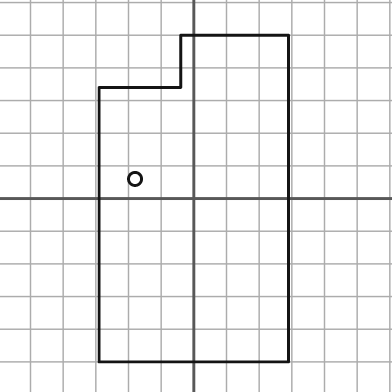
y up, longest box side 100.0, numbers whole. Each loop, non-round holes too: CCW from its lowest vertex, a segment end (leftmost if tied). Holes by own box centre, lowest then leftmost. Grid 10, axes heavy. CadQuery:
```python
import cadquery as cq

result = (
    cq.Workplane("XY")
    .moveTo(-29.0, -50.0)
    .lineTo(29.0, -50.0)
    .lineTo(29.0, 50.0)
    .lineTo(-4.0, 50.0)
    .lineTo(-4.0, 34.0)
    .lineTo(-29.0, 34.0)
    .close()
    .moveTo(-18.0, 6.0)
    .circle(2.0)
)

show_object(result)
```